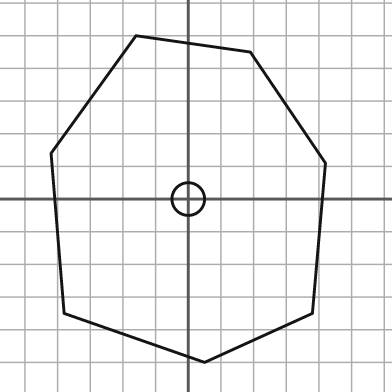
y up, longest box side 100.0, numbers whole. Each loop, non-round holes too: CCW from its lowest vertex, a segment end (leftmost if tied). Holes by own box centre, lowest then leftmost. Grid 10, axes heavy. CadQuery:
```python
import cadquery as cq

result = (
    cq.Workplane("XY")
    .moveTo(5.0, -50.0)
    .lineTo(38.0, -35.0)
    .lineTo(42.0, 11.0)
    .lineTo(19.0, 45.0)
    .lineTo(-16.0, 50.0)
    .lineTo(-42.0, 14.0)
    .lineTo(-38.0, -35.0)
    .close()
    .moveTo(0.0, 0.0)
    .circle(5.0)
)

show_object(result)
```